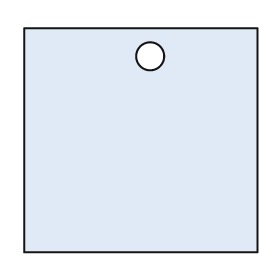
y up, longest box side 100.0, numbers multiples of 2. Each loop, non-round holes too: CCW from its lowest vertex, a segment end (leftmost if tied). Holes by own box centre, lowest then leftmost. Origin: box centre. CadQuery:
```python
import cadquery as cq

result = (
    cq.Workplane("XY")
    .moveTo(-50.0, -48.0)
    .lineTo(50.0, -48.0)
    .lineTo(50.0, 48.0)
    .lineTo(-50.0, 48.0)
    .close()
    .moveTo(4.0, 36.0)
    .circle(6.0)
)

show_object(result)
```